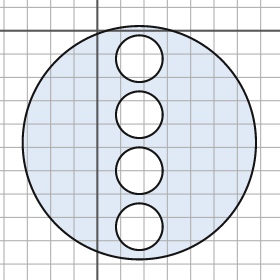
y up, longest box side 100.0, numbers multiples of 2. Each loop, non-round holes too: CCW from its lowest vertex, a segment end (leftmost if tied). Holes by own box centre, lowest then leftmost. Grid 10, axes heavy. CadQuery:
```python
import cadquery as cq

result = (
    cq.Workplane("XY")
    .moveTo(18.0, -48.0)
    .circle(50.0)
    .moveTo(18.0, -84.0)
    .circle(10.0)
    .moveTo(18.0, -60.0)
    .circle(10.0)
    .moveTo(18.0, -36.0)
    .circle(10.0)
    .moveTo(18.0, -12.0)
    .circle(10.0)
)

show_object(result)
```